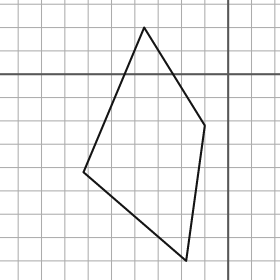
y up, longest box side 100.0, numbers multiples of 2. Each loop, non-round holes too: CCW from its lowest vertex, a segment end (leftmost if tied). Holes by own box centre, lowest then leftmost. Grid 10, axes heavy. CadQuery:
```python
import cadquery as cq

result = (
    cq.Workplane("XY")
    .moveTo(-18.0, -80.0)
    .lineTo(-10.0, -22.0)
    .lineTo(-36.0, 20.0)
    .lineTo(-62.0, -42.0)
    .close()
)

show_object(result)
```